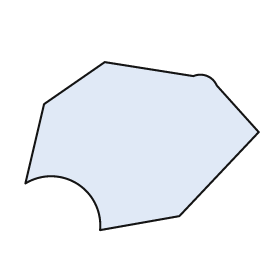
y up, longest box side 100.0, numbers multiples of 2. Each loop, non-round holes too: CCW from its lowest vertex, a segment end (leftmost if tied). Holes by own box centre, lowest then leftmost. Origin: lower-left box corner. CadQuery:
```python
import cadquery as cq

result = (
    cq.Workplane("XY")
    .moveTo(32.0, 0.0)
    .lineTo(66.0, 6.0)
    .lineTo(100.0, 42.0)
    .lineTo(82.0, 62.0)
    .threePointArc((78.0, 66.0), (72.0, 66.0))
    .lineTo(34.0, 72.0)
    .lineTo(8.0, 54.0)
    .lineTo(0.0, 20.0)
    .threePointArc((22.0, 20.0), (32.0, 0.0))
    .close()
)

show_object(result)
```